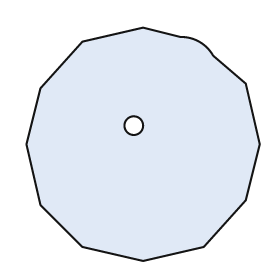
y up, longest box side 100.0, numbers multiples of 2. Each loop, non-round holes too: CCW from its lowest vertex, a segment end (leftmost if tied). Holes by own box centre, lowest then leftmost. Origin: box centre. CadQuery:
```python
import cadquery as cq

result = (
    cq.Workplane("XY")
    .moveTo(0.0, -50.0)
    .lineTo(26.0, -44.0)
    .lineTo(44.0, -24.0)
    .lineTo(50.0, 0.0)
    .lineTo(44.0, 26.0)
    .lineTo(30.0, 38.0)
    .threePointArc((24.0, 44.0), (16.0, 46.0))
    .lineTo(0.0, 50.0)
    .lineTo(-26.0, 44.0)
    .lineTo(-44.0, 24.0)
    .lineTo(-50.0, 0.0)
    .lineTo(-44.0, -26.0)
    .lineTo(-26.0, -44.0)
    .close()
    .moveTo(-4.0, 8.0)
    .circle(4.0)
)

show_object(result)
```